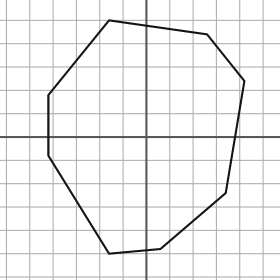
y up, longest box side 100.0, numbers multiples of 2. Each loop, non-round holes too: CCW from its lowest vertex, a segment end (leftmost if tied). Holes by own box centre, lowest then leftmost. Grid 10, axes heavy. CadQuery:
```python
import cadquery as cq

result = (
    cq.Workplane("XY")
    .moveTo(-16.0, -50.0)
    .lineTo(6.0, -48.0)
    .lineTo(34.0, -24.0)
    .lineTo(42.0, 24.0)
    .lineTo(26.0, 44.0)
    .lineTo(-16.0, 50.0)
    .lineTo(-42.0, 18.0)
    .lineTo(-42.0, -8.0)
    .close()
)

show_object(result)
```